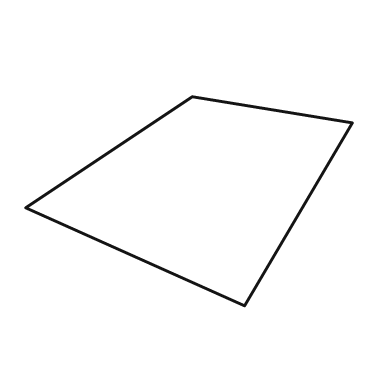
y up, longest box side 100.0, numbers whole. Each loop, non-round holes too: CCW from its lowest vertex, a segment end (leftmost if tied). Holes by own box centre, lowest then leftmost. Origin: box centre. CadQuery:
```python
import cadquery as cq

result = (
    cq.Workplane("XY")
    .moveTo(17.0, -32.0)
    .lineTo(50.0, 24.0)
    .lineTo(1.0, 32.0)
    .lineTo(-50.0, -2.0)
    .close()
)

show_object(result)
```